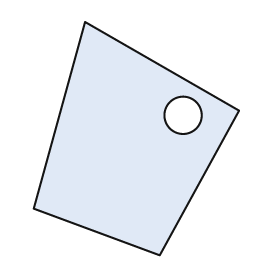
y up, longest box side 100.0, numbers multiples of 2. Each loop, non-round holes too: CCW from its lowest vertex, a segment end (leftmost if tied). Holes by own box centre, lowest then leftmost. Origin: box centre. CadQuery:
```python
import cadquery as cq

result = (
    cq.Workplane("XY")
    .moveTo(10.0, -50.0)
    .lineTo(44.0, 12.0)
    .lineTo(-22.0, 50.0)
    .lineTo(-44.0, -30.0)
    .close()
    .moveTo(20.0, 10.0)
    .circle(8.0)
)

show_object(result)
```